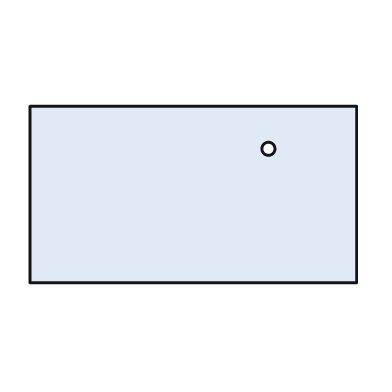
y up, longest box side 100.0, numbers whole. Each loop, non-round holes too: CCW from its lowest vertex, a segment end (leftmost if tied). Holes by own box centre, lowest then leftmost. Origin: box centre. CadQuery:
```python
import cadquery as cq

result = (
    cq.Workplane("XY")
    .moveTo(-50.0, -27.0)
    .lineTo(50.0, -27.0)
    .lineTo(50.0, 27.0)
    .lineTo(-50.0, 27.0)
    .close()
    .moveTo(23.0, 14.0)
    .circle(2.0)
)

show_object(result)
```